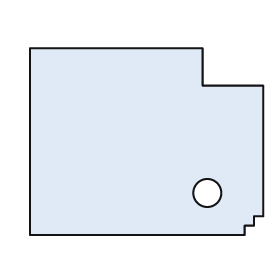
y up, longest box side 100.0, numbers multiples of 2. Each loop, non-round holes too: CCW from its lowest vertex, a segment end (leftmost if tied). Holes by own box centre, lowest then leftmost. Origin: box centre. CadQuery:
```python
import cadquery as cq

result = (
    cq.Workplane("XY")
    .moveTo(-50.0, -40.0)
    .lineTo(42.0, -40.0)
    .lineTo(42.0, -36.0)
    .lineTo(46.0, -36.0)
    .lineTo(46.0, -32.0)
    .lineTo(50.0, -32.0)
    .lineTo(50.0, 24.0)
    .lineTo(24.0, 24.0)
    .lineTo(24.0, 40.0)
    .lineTo(-50.0, 40.0)
    .close()
    .moveTo(26.0, -22.0)
    .circle(6.0)
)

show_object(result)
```